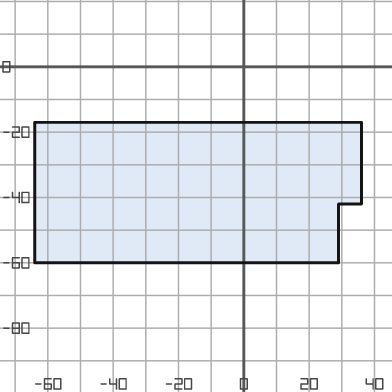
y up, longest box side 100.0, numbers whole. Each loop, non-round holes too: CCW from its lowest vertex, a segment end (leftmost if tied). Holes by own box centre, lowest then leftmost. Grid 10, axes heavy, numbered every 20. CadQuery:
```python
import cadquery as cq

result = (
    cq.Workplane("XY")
    .moveTo(-64.0, -60.0)
    .lineTo(29.0, -60.0)
    .lineTo(29.0, -42.0)
    .lineTo(36.0, -42.0)
    .lineTo(36.0, -17.0)
    .lineTo(-64.0, -17.0)
    .close()
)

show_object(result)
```